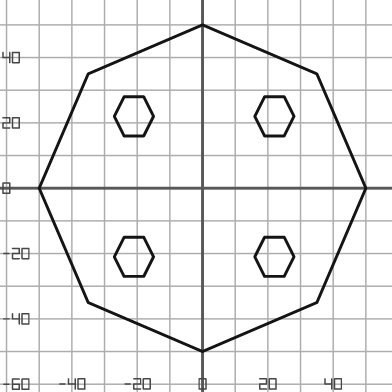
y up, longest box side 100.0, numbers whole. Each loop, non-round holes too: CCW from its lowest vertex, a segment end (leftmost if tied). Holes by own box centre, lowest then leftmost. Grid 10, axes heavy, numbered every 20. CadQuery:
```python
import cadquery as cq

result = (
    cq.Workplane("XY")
    .moveTo(0.0, -50.0)
    .lineTo(35.0, -35.0)
    .lineTo(50.0, 0.0)
    .lineTo(35.0, 35.0)
    .lineTo(0.0, 50.0)
    .lineTo(-35.0, 35.0)
    .lineTo(-50.0, 0.0)
    .lineTo(-35.0, -35.0)
    .close()
    .moveTo(-24.0, -27.0)
    .lineTo(-18.0, -27.0)
    .lineTo(-15.0, -21.0)
    .lineTo(-18.0, -15.0)
    .lineTo(-24.0, -15.0)
    .lineTo(-27.0, -21.0)
    .close()
    .moveTo(19.0, -27.0)
    .lineTo(25.0, -27.0)
    .lineTo(28.0, -21.0)
    .lineTo(25.0, -15.0)
    .lineTo(19.0, -15.0)
    .lineTo(16.0, -21.0)
    .close()
    .moveTo(-24.0, 16.0)
    .lineTo(-18.0, 16.0)
    .lineTo(-15.0, 22.0)
    .lineTo(-18.0, 28.0)
    .lineTo(-24.0, 28.0)
    .lineTo(-27.0, 22.0)
    .close()
    .moveTo(19.0, 16.0)
    .lineTo(25.0, 16.0)
    .lineTo(28.0, 22.0)
    .lineTo(25.0, 28.0)
    .lineTo(19.0, 28.0)
    .lineTo(16.0, 22.0)
    .close()
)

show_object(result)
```